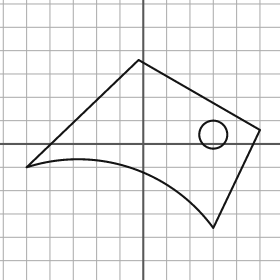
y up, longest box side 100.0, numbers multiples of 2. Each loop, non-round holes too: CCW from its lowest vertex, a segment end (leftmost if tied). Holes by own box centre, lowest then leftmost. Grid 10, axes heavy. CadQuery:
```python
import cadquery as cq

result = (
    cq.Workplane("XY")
    .moveTo(30.0, -36.0)
    .lineTo(50.0, 6.0)
    .lineTo(-2.0, 36.0)
    .lineTo(-50.0, -10.0)
    .threePointArc((-6.0, -10.0), (30.0, -36.0))
    .close()
    .moveTo(30.0, 4.0)
    .circle(6.0)
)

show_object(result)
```